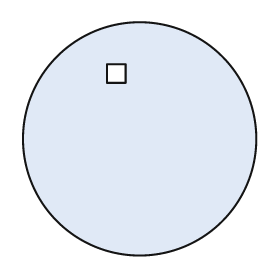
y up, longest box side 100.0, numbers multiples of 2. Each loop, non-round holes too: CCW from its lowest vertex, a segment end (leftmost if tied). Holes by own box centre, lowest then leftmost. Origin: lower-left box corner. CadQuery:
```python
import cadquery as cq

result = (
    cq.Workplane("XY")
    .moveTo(50.0, 50.0)
    .circle(50.0)
    .moveTo(36.0, 74.0)
    .lineTo(44.0, 74.0)
    .lineTo(44.0, 82.0)
    .lineTo(36.0, 82.0)
    .close()
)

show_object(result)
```